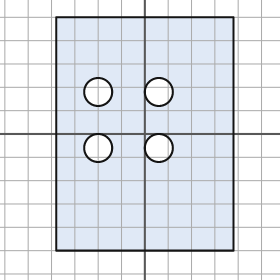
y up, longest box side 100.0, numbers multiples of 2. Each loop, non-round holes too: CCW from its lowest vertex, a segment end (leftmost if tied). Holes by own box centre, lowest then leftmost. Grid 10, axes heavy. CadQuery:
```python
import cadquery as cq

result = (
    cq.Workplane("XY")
    .moveTo(-38.0, -50.0)
    .lineTo(38.0, -50.0)
    .lineTo(38.0, 50.0)
    .lineTo(-38.0, 50.0)
    .close()
    .moveTo(-20.0, -6.0)
    .circle(6.0)
    .moveTo(6.0, -6.0)
    .circle(6.0)
    .moveTo(-20.0, 18.0)
    .circle(6.0)
    .moveTo(6.0, 18.0)
    .circle(6.0)
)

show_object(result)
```